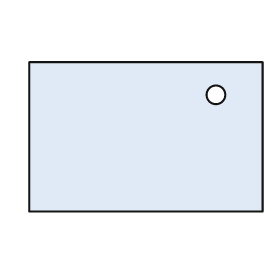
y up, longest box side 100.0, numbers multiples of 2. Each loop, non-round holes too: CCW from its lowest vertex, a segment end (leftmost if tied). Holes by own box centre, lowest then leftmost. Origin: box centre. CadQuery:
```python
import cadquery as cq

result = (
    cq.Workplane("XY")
    .moveTo(-50.0, -32.0)
    .lineTo(50.0, -32.0)
    .lineTo(50.0, 32.0)
    .lineTo(-50.0, 32.0)
    .close()
    .moveTo(30.0, 18.0)
    .circle(4.0)
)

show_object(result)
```